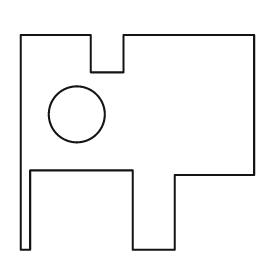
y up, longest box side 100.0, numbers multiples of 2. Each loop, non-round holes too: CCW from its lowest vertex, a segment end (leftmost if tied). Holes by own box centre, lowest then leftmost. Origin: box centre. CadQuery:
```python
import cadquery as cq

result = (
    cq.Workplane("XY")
    .moveTo(-50.0, -46.0)
    .lineTo(-46.0, -46.0)
    .lineTo(-46.0, -12.0)
    .lineTo(-2.0, -12.0)
    .lineTo(-2.0, -46.0)
    .lineTo(16.0, -46.0)
    .lineTo(16.0, -14.0)
    .lineTo(50.0, -14.0)
    .lineTo(50.0, 46.0)
    .lineTo(-6.0, 46.0)
    .lineTo(-6.0, 30.0)
    .lineTo(-20.0, 30.0)
    .lineTo(-20.0, 46.0)
    .lineTo(-50.0, 46.0)
    .close()
    .moveTo(-26.0, 12.0)
    .circle(12.0)
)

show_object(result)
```